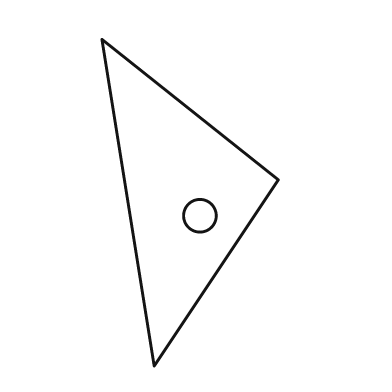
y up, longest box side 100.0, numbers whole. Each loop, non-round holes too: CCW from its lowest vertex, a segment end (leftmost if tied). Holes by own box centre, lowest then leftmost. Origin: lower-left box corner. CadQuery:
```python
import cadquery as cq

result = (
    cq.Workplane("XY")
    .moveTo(16.0, 0.0)
    .lineTo(54.0, 57.0)
    .lineTo(0.0, 100.0)
    .close()
    .moveTo(30.0, 46.0)
    .circle(5.0)
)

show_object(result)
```